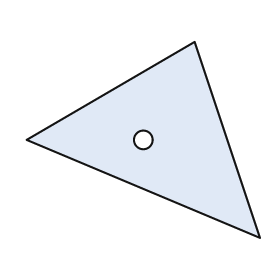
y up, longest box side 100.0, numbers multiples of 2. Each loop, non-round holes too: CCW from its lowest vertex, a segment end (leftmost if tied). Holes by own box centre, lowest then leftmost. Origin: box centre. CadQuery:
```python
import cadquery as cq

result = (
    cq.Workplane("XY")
    .moveTo(50.0, -42.0)
    .lineTo(22.0, 42.0)
    .lineTo(-50.0, 0.0)
    .close()
    .moveTo(0.0, 0.0)
    .circle(4.0)
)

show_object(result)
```